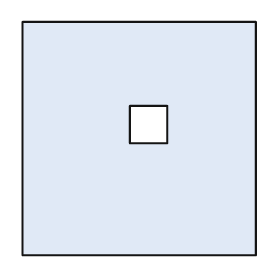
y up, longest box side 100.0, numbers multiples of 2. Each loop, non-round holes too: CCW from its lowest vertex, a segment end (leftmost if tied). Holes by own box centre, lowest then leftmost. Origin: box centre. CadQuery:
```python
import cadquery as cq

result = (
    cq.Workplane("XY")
    .moveTo(-50.0, -50.0)
    .lineTo(50.0, -50.0)
    .lineTo(50.0, 50.0)
    .lineTo(-50.0, 50.0)
    .close()
    .moveTo(-4.0, -2.0)
    .lineTo(12.0, -2.0)
    .lineTo(12.0, 14.0)
    .lineTo(-4.0, 14.0)
    .close()
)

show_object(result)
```